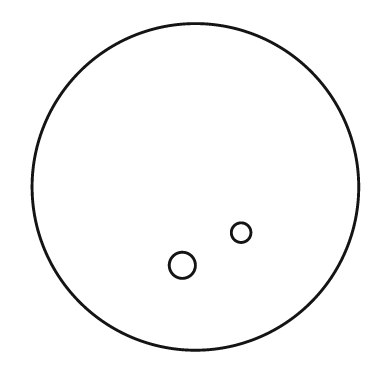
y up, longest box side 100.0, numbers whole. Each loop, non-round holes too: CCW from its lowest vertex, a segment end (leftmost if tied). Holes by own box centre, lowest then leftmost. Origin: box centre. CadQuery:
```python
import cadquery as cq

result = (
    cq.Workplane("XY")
    .moveTo(0.0, 0.0)
    .circle(50.0)
    .moveTo(-4.0, -24.0)
    .circle(4.0)
    .moveTo(14.0, -14.0)
    .circle(3.0)
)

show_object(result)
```